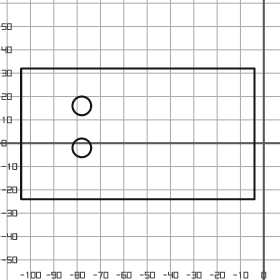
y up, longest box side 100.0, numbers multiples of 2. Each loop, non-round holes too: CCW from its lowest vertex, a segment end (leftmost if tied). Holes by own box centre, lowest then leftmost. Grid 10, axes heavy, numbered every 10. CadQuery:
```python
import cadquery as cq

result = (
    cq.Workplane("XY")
    .moveTo(-104.0, -24.0)
    .lineTo(-4.0, -24.0)
    .lineTo(-4.0, 32.0)
    .lineTo(-104.0, 32.0)
    .close()
    .moveTo(-78.0, -2.0)
    .circle(4.0)
    .moveTo(-78.0, 16.0)
    .circle(4.0)
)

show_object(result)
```